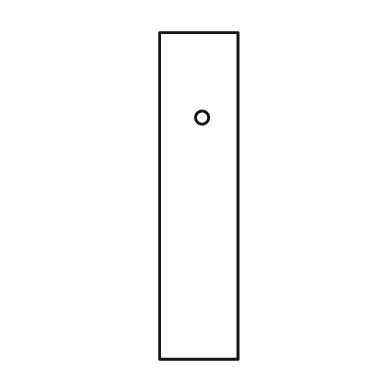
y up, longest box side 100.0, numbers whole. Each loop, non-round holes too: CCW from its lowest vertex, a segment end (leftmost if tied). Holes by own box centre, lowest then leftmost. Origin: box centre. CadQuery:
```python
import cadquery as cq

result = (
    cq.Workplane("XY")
    .moveTo(-12.0, -50.0)
    .lineTo(12.0, -50.0)
    .lineTo(12.0, 50.0)
    .lineTo(-12.0, 50.0)
    .close()
    .moveTo(1.0, 24.0)
    .circle(2.0)
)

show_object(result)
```